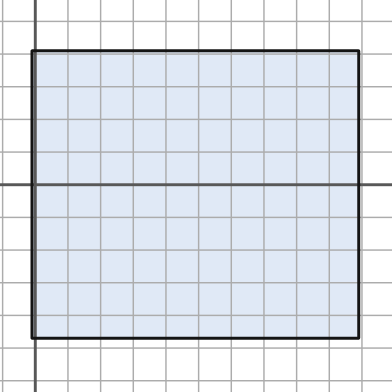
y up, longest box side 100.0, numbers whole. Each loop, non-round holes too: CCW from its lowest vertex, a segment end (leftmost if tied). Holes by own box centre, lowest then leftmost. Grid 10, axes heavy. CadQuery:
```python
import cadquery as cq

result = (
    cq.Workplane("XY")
    .moveTo(-1.0, -47.0)
    .lineTo(99.0, -47.0)
    .lineTo(99.0, 41.0)
    .lineTo(-1.0, 41.0)
    .close()
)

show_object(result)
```